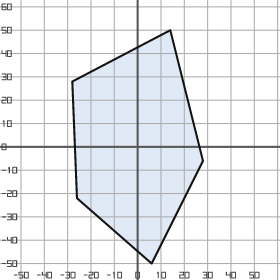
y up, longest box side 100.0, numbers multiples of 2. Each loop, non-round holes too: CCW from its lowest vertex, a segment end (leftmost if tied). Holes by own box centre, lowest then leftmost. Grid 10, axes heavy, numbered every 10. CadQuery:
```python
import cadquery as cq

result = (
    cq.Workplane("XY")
    .moveTo(6.0, -50.0)
    .lineTo(28.0, -6.0)
    .lineTo(14.0, 50.0)
    .lineTo(-28.0, 28.0)
    .lineTo(-26.0, -22.0)
    .close()
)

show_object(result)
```